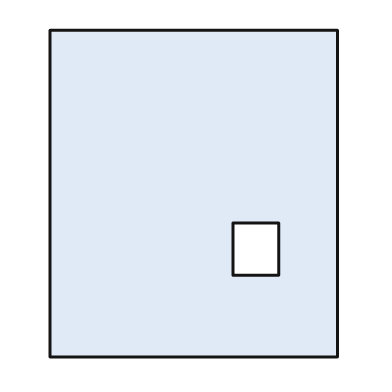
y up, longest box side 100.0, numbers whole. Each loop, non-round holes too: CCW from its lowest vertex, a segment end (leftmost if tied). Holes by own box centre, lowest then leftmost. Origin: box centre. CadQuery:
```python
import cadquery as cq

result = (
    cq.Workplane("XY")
    .moveTo(-44.0, -50.0)
    .lineTo(44.0, -50.0)
    .lineTo(44.0, 50.0)
    .lineTo(-44.0, 50.0)
    .close()
    .moveTo(12.0, -25.0)
    .lineTo(26.0, -25.0)
    .lineTo(26.0, -9.0)
    .lineTo(12.0, -9.0)
    .close()
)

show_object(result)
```